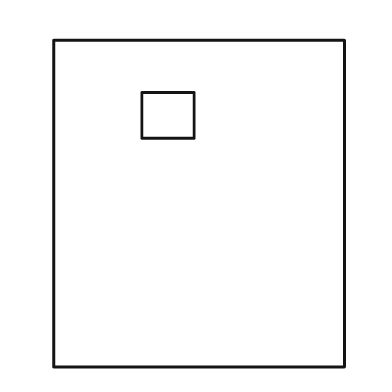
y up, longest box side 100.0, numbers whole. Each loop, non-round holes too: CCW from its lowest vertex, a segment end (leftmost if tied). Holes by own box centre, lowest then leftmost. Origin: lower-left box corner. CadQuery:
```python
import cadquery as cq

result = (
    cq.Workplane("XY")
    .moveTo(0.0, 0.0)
    .lineTo(89.0, 0.0)
    .lineTo(89.0, 100.0)
    .lineTo(0.0, 100.0)
    .close()
    .moveTo(27.0, 70.0)
    .lineTo(43.0, 70.0)
    .lineTo(43.0, 84.0)
    .lineTo(27.0, 84.0)
    .close()
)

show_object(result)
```